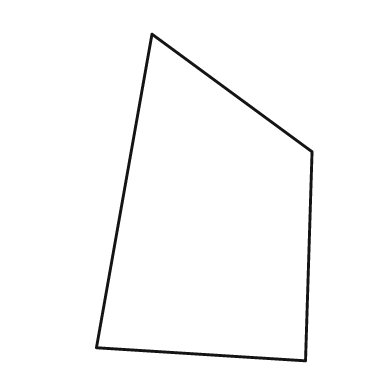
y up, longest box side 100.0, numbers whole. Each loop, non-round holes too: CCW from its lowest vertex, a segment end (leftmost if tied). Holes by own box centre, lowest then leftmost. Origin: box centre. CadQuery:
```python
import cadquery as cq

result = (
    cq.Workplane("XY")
    .moveTo(31.0, -50.0)
    .lineTo(33.0, 14.0)
    .lineTo(-16.0, 50.0)
    .lineTo(-33.0, -46.0)
    .close()
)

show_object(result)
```